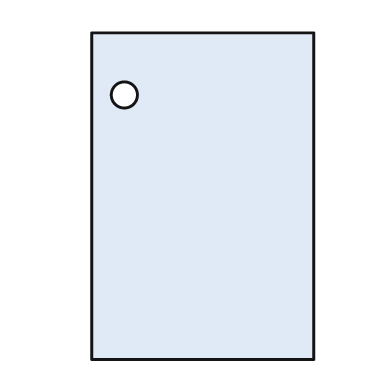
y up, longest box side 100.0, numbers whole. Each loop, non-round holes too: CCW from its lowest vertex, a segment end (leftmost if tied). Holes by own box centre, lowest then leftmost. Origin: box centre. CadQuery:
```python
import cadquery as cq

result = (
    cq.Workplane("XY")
    .moveTo(-34.0, -50.0)
    .lineTo(34.0, -50.0)
    .lineTo(34.0, 50.0)
    .lineTo(-34.0, 50.0)
    .close()
    .moveTo(-24.0, 31.0)
    .circle(4.0)
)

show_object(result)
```